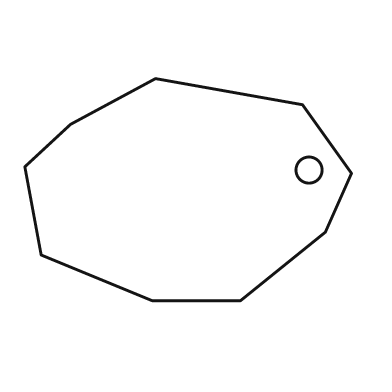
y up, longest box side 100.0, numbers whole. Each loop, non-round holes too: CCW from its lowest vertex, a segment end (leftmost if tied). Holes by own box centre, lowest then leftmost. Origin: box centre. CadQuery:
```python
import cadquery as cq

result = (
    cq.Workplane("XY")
    .moveTo(-11.0, -34.0)
    .lineTo(16.0, -34.0)
    .lineTo(42.0, -13.0)
    .lineTo(50.0, 5.0)
    .lineTo(35.0, 26.0)
    .lineTo(-10.0, 34.0)
    .lineTo(-36.0, 20.0)
    .lineTo(-50.0, 7.0)
    .lineTo(-45.0, -20.0)
    .close()
    .moveTo(37.0, 6.0)
    .circle(4.0)
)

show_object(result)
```